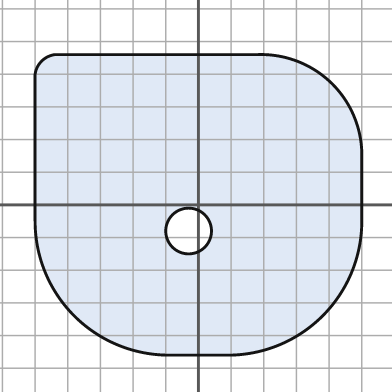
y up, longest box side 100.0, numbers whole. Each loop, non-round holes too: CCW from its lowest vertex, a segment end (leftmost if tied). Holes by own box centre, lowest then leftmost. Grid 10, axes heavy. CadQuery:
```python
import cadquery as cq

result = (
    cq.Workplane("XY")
    .moveTo(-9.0, -46.0)
    .lineTo(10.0, -46.0)
    .threePointArc((38.0, -34.0), (50.0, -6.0))
    .lineTo(50.0, 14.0)
    .threePointArc((41.0, 37.0), (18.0, 46.0))
    .lineTo(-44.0, 46.0)
    .threePointArc((-48.0, 44.0), (-50.0, 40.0))
    .lineTo(-50.0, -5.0)
    .threePointArc((-38.0, -34.0), (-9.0, -46.0))
    .close()
    .moveTo(-3.0, -8.0)
    .circle(7.0)
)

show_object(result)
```